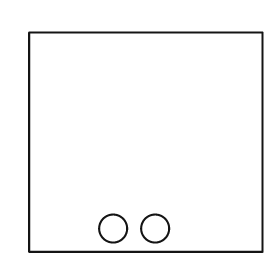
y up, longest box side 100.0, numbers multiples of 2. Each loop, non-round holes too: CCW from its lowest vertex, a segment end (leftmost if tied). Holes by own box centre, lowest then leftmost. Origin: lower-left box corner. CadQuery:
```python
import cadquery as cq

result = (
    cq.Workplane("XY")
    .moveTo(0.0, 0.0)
    .lineTo(100.0, 0.0)
    .lineTo(100.0, 94.0)
    .lineTo(0.0, 94.0)
    .close()
    .moveTo(36.0, 10.0)
    .circle(6.0)
    .moveTo(54.0, 10.0)
    .circle(6.0)
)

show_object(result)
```